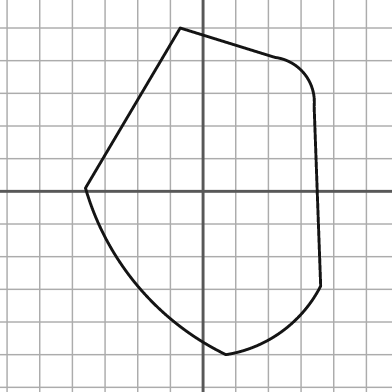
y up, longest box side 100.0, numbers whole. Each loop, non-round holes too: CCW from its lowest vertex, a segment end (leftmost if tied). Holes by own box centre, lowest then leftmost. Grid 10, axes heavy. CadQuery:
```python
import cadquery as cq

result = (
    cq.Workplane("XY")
    .moveTo(7.0, -50.0)
    .threePointArc((24.0, -43.0), (36.0, -29.0))
    .lineTo(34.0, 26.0)
    .threePointArc((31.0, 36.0), (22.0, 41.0))
    .lineTo(-7.0, 50.0)
    .lineTo(-36.0, 1.0)
    .threePointArc((-20.0, -29.0), (7.0, -50.0))
    .close()
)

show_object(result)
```